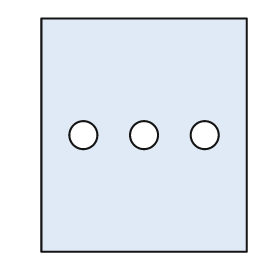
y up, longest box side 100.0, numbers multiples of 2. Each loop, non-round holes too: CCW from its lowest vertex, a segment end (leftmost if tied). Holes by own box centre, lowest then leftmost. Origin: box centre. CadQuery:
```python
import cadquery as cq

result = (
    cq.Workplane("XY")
    .moveTo(-44.0, -50.0)
    .lineTo(44.0, -50.0)
    .lineTo(44.0, 50.0)
    .lineTo(-44.0, 50.0)
    .close()
    .moveTo(-26.0, 0.0)
    .circle(6.0)
    .moveTo(0.0, 0.0)
    .circle(6.0)
    .moveTo(26.0, 0.0)
    .circle(6.0)
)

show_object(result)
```